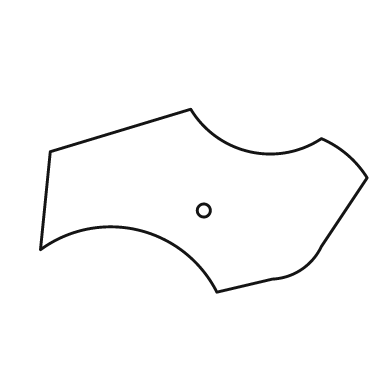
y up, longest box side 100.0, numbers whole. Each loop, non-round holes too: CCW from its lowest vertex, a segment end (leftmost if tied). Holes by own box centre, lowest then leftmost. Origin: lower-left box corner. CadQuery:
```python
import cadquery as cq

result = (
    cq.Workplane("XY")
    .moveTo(54.0, 0.0)
    .lineTo(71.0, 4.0)
    .threePointArc((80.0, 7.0), (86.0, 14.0))
    .lineTo(100.0, 35.0)
    .threePointArc((94.0, 42.0), (86.0, 47.0))
    .threePointArc((64.0, 43.0), (46.0, 56.0))
    .lineTo(3.0, 43.0)
    .lineTo(0.0, 13.0)
    .threePointArc((30.0, 19.0), (54.0, 0.0))
    .close()
    .moveTo(50.0, 25.0)
    .circle(2.0)
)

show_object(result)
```